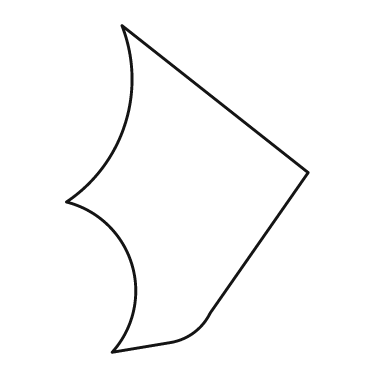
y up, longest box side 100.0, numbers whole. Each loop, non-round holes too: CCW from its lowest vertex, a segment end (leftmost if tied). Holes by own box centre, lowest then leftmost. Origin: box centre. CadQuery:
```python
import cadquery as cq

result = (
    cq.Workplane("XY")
    .moveTo(-23.0, -50.0)
    .lineTo(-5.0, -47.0)
    .threePointArc((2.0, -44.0), (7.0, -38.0))
    .lineTo(37.0, 5.0)
    .lineTo(-20.0, 50.0)
    .threePointArc((-19.0, 20.0), (-37.0, -4.0))
    .threePointArc((-17.0, -23.0), (-23.0, -50.0))
    .close()
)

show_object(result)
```